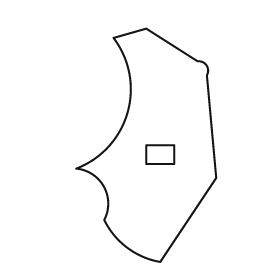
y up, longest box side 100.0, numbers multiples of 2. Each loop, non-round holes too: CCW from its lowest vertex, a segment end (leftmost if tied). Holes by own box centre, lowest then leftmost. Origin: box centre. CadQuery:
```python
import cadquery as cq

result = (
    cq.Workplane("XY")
    .moveTo(6.0, -50.0)
    .lineTo(30.0, -14.0)
    .lineTo(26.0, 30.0)
    .threePointArc((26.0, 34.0), (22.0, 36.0))
    .lineTo(0.0, 50.0)
    .lineTo(-14.0, 46.0)
    .threePointArc((-8.0, 14.0), (-30.0, -10.0))
    .threePointArc((-18.0, -18.0), (-18.0, -32.0))
    .threePointArc((-8.0, -44.0), (6.0, -50.0))
    .close()
    .moveTo(0.0, -8.0)
    .lineTo(12.0, -8.0)
    .lineTo(12.0, 0.0)
    .lineTo(0.0, 0.0)
    .close()
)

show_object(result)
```